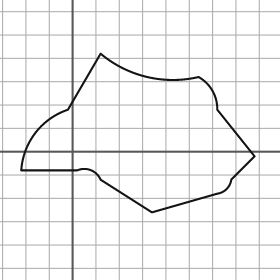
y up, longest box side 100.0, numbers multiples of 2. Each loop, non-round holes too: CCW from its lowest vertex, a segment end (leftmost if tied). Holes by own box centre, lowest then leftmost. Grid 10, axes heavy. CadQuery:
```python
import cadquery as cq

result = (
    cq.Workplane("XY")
    .moveTo(34.0, -26.0)
    .lineTo(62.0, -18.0)
    .threePointArc((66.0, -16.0), (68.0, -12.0))
    .lineTo(78.0, -2.0)
    .lineTo(62.0, 18.0)
    .threePointArc((60.0, 26.0), (54.0, 32.0))
    .threePointArc((32.0, 32.0), (12.0, 42.0))
    .lineTo(-2.0, 18.0)
    .threePointArc((-16.0, 8.0), (-22.0, -8.0))
    .lineTo(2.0, -8.0)
    .threePointArc((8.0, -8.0), (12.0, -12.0))
    .close()
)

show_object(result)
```